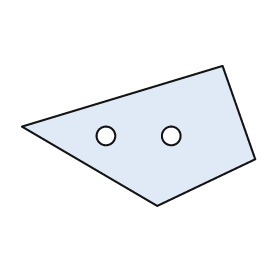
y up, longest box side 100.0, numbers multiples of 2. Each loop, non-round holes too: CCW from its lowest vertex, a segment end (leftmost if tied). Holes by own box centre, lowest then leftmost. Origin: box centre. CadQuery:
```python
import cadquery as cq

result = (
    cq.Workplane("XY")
    .moveTo(8.0, -30.0)
    .lineTo(50.0, -10.0)
    .lineTo(36.0, 30.0)
    .lineTo(-50.0, 4.0)
    .close()
    .moveTo(-14.0, 0.0)
    .circle(4.0)
    .moveTo(14.0, 0.0)
    .circle(4.0)
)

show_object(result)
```